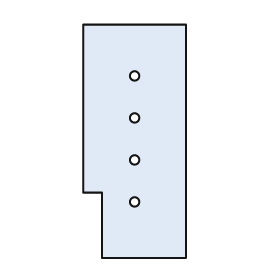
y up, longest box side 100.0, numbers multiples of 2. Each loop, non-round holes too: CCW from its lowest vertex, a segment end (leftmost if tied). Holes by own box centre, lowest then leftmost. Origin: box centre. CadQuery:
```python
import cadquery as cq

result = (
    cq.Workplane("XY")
    .moveTo(-14.0, -50.0)
    .lineTo(22.0, -50.0)
    .lineTo(22.0, 50.0)
    .lineTo(-22.0, 50.0)
    .lineTo(-22.0, -22.0)
    .lineTo(-14.0, -22.0)
    .close()
    .moveTo(0.0, -26.0)
    .circle(2.0)
    .moveTo(0.0, -8.0)
    .circle(2.0)
    .moveTo(0.0, 10.0)
    .circle(2.0)
    .moveTo(0.0, 28.0)
    .circle(2.0)
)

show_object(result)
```